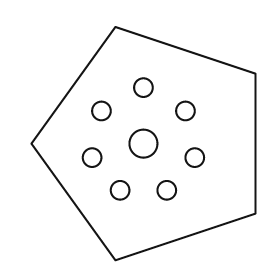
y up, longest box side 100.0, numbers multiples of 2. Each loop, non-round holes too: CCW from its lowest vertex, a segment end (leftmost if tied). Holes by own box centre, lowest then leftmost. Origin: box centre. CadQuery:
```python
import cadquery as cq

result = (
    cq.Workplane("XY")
    .moveTo(-12.0, -50.0)
    .lineTo(48.0, -30.0)
    .lineTo(48.0, 30.0)
    .lineTo(-12.0, 50.0)
    .lineTo(-48.0, 0.0)
    .close()
    .moveTo(-10.0, -20.0)
    .circle(4.0)
    .moveTo(10.0, -20.0)
    .circle(4.0)
    .moveTo(-22.0, -6.0)
    .circle(4.0)
    .moveTo(22.0, -6.0)
    .circle(4.0)
    .moveTo(0.0, 0.0)
    .circle(6.0)
    .moveTo(-18.0, 14.0)
    .circle(4.0)
    .moveTo(18.0, 14.0)
    .circle(4.0)
    .moveTo(0.0, 24.0)
    .circle(4.0)
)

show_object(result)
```